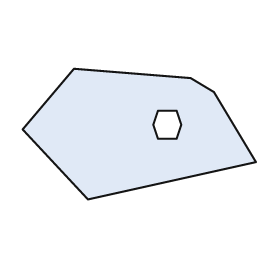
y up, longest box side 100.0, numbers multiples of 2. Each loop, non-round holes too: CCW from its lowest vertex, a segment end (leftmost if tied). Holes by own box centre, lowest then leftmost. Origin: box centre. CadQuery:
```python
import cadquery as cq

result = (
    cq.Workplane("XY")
    .moveTo(-22.0, -28.0)
    .lineTo(50.0, -12.0)
    .lineTo(32.0, 18.0)
    .lineTo(22.0, 24.0)
    .lineTo(-28.0, 28.0)
    .lineTo(-50.0, 2.0)
    .close()
    .moveTo(8.0, -2.0)
    .lineTo(16.0, -2.0)
    .lineTo(18.0, 4.0)
    .lineTo(16.0, 10.0)
    .lineTo(8.0, 10.0)
    .lineTo(6.0, 4.0)
    .close()
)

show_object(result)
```